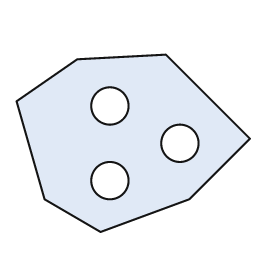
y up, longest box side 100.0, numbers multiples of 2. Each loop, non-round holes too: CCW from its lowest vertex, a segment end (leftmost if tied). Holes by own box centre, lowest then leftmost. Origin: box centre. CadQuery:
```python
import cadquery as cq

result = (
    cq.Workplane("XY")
    .moveTo(-14.0, -38.0)
    .lineTo(24.0, -24.0)
    .lineTo(50.0, 2.0)
    .lineTo(14.0, 38.0)
    .lineTo(-24.0, 36.0)
    .lineTo(-50.0, 18.0)
    .lineTo(-38.0, -24.0)
    .close()
    .moveTo(-10.0, -16.0)
    .circle(8.0)
    .moveTo(20.0, 0.0)
    .circle(8.0)
    .moveTo(-10.0, 16.0)
    .circle(8.0)
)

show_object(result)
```